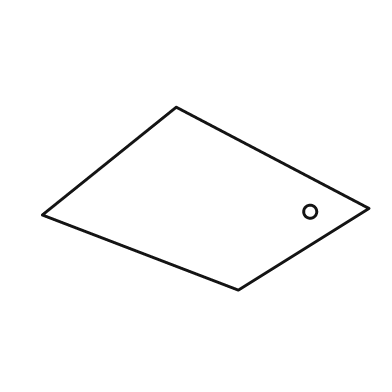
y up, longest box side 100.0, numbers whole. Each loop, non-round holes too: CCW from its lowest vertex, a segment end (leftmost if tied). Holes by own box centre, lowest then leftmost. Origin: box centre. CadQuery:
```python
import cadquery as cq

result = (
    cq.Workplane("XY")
    .moveTo(10.0, -28.0)
    .lineTo(50.0, -3.0)
    .lineTo(-9.0, 28.0)
    .lineTo(-50.0, -5.0)
    .close()
    .moveTo(32.0, -4.0)
    .circle(2.0)
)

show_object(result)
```